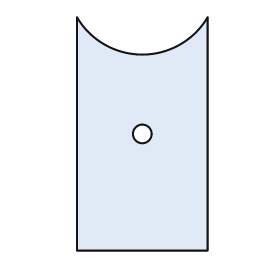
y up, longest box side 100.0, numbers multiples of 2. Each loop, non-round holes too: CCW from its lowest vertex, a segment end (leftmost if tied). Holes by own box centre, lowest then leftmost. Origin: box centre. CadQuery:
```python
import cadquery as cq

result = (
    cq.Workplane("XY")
    .moveTo(-28.0, -50.0)
    .lineTo(28.0, -50.0)
    .lineTo(28.0, 50.0)
    .threePointArc((0.0, 34.0), (-28.0, 50.0))
    .close()
    .moveTo(0.0, 0.0)
    .circle(4.0)
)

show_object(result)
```